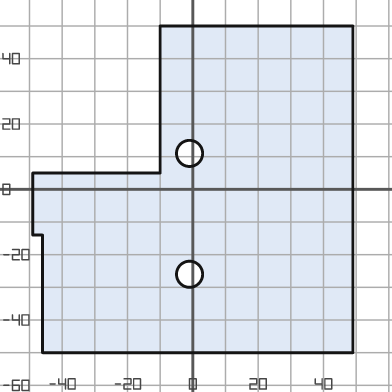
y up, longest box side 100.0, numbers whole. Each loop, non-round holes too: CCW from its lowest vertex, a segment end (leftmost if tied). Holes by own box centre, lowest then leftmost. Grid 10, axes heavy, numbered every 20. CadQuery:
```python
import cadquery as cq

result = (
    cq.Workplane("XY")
    .moveTo(-46.0, -50.0)
    .lineTo(49.0, -50.0)
    .lineTo(49.0, 50.0)
    .lineTo(-10.0, 50.0)
    .lineTo(-10.0, 5.0)
    .lineTo(-49.0, 5.0)
    .lineTo(-49.0, -14.0)
    .lineTo(-46.0, -14.0)
    .close()
    .moveTo(-1.0, -26.0)
    .circle(4.0)
    .moveTo(-1.0, 11.0)
    .circle(4.0)
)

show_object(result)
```